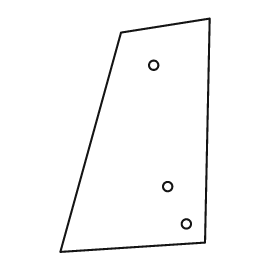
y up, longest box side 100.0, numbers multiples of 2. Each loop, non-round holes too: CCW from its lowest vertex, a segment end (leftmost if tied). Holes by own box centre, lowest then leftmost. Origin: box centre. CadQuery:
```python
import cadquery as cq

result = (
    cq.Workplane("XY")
    .moveTo(-32.0, -50.0)
    .lineTo(30.0, -46.0)
    .lineTo(32.0, 50.0)
    .lineTo(-6.0, 44.0)
    .close()
    .moveTo(22.0, -38.0)
    .circle(2.0)
    .moveTo(14.0, -22.0)
    .circle(2.0)
    .moveTo(8.0, 30.0)
    .circle(2.0)
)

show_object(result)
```